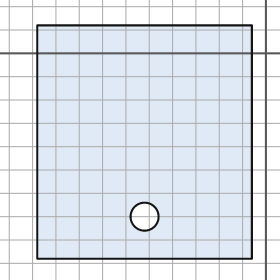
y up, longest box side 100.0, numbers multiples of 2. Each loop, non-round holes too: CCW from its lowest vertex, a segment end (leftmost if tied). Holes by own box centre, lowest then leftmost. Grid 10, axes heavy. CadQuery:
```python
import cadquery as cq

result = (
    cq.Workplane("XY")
    .moveTo(-98.0, -88.0)
    .lineTo(-6.0, -88.0)
    .lineTo(-6.0, 12.0)
    .lineTo(-98.0, 12.0)
    .close()
    .moveTo(-52.0, -70.0)
    .circle(6.0)
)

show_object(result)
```